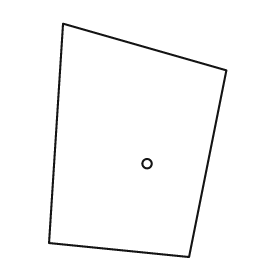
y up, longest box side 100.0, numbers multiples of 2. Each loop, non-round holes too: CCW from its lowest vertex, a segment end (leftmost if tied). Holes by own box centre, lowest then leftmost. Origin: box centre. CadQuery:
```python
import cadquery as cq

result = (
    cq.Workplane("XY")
    .moveTo(22.0, -50.0)
    .lineTo(38.0, 30.0)
    .lineTo(-32.0, 50.0)
    .lineTo(-38.0, -44.0)
    .close()
    .moveTo(4.0, -10.0)
    .circle(2.0)
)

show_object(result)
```